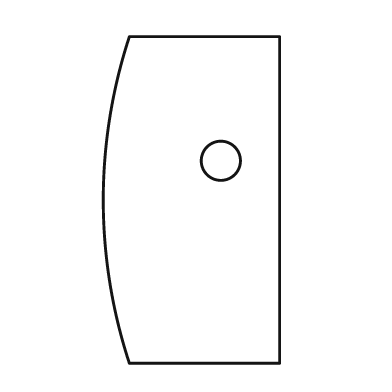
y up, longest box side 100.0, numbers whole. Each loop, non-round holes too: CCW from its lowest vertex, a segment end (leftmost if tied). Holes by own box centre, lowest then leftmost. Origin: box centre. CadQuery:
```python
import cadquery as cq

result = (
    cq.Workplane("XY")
    .moveTo(-19.0, -50.0)
    .lineTo(27.0, -50.0)
    .lineTo(27.0, 50.0)
    .lineTo(-19.0, 50.0)
    .threePointArc((-27.0, 0.0), (-19.0, -50.0))
    .close()
    .moveTo(9.0, 12.0)
    .circle(6.0)
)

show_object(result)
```